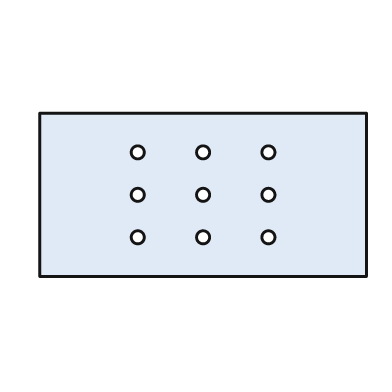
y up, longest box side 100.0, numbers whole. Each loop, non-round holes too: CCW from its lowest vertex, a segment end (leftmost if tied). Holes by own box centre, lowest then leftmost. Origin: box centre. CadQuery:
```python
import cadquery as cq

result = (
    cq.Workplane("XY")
    .moveTo(-50.0, -25.0)
    .lineTo(50.0, -25.0)
    .lineTo(50.0, 25.0)
    .lineTo(-50.0, 25.0)
    .close()
    .moveTo(-20.0, -13.0)
    .circle(2.0)
    .moveTo(0.0, -13.0)
    .circle(2.0)
    .moveTo(20.0, -13.0)
    .circle(2.0)
    .moveTo(-20.0, 0.0)
    .circle(2.0)
    .moveTo(0.0, 0.0)
    .circle(2.0)
    .moveTo(20.0, 0.0)
    .circle(2.0)
    .moveTo(-20.0, 13.0)
    .circle(2.0)
    .moveTo(0.0, 13.0)
    .circle(2.0)
    .moveTo(20.0, 13.0)
    .circle(2.0)
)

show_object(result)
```